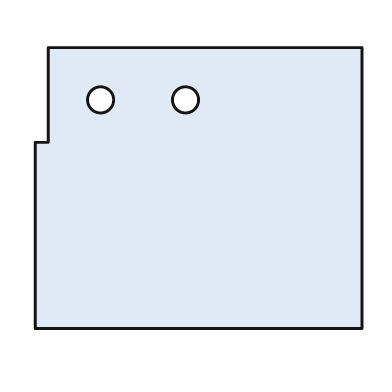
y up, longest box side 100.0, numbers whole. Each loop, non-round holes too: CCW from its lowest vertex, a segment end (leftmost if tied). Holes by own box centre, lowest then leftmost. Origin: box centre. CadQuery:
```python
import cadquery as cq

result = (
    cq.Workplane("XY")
    .moveTo(-50.0, -43.0)
    .lineTo(50.0, -43.0)
    .lineTo(50.0, 43.0)
    .lineTo(-46.0, 43.0)
    .lineTo(-46.0, 14.0)
    .lineTo(-50.0, 14.0)
    .close()
    .moveTo(-30.0, 27.0)
    .circle(4.0)
    .moveTo(-4.0, 27.0)
    .circle(4.0)
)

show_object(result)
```